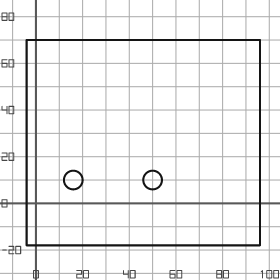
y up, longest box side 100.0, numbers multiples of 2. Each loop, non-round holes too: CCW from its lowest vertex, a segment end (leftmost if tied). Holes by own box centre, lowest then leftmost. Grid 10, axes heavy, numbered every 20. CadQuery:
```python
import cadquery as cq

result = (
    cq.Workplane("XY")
    .moveTo(-4.0, -18.0)
    .lineTo(96.0, -18.0)
    .lineTo(96.0, 70.0)
    .lineTo(-4.0, 70.0)
    .close()
    .moveTo(16.0, 10.0)
    .circle(4.0)
    .moveTo(50.0, 10.0)
    .circle(4.0)
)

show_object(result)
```